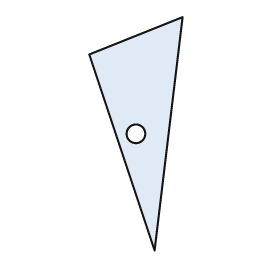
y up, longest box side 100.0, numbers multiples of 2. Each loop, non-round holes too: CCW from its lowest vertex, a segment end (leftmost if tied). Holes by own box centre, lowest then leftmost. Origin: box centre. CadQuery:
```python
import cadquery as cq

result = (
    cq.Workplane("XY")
    .moveTo(8.0, -50.0)
    .lineTo(20.0, 50.0)
    .lineTo(-20.0, 34.0)
    .close()
    .moveTo(0.0, 0.0)
    .circle(4.0)
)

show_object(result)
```